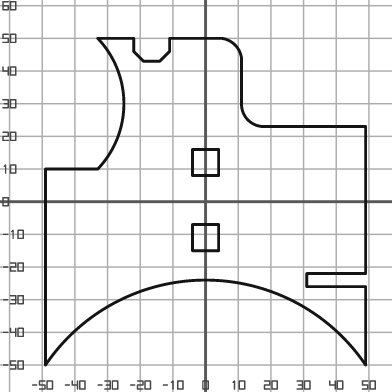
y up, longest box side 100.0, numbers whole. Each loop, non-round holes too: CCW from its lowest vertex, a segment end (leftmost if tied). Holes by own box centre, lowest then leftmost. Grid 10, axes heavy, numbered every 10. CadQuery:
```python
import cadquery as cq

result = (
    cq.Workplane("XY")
    .moveTo(-49.0, -50.0)
    .threePointArc((0.0, -24.0), (49.0, -50.0))
    .lineTo(49.0, -26.0)
    .lineTo(31.0, -26.0)
    .lineTo(31.0, -22.0)
    .lineTo(49.0, -22.0)
    .lineTo(49.0, 23.0)
    .lineTo(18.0, 23.0)
    .threePointArc((13.0, 25.0), (11.0, 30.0))
    .lineTo(11.0, 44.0)
    .threePointArc((9.0, 48.0), (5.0, 50.0))
    .lineTo(-11.0, 50.0)
    .lineTo(-11.0, 46.0)
    .lineTo(-14.0, 43.0)
    .lineTo(-19.0, 43.0)
    .lineTo(-22.0, 46.0)
    .lineTo(-22.0, 50.0)
    .lineTo(-33.0, 50.0)
    .threePointArc((-25.0, 30.0), (-33.0, 10.0))
    .lineTo(-49.0, 10.0)
    .close()
    .moveTo(-4.0, -15.0)
    .lineTo(4.0, -15.0)
    .lineTo(4.0, -7.0)
    .lineTo(-4.0, -7.0)
    .close()
    .moveTo(-4.0, 8.0)
    .lineTo(4.0, 8.0)
    .lineTo(4.0, 16.0)
    .lineTo(-4.0, 16.0)
    .close()
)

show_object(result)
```